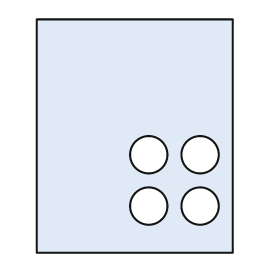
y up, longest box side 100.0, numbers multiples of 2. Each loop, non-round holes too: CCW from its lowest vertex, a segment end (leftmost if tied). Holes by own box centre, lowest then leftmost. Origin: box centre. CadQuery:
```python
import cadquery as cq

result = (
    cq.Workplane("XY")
    .moveTo(-42.0, -50.0)
    .lineTo(42.0, -50.0)
    .lineTo(42.0, 50.0)
    .lineTo(-42.0, 50.0)
    .close()
    .moveTo(6.0, -30.0)
    .circle(8.0)
    .moveTo(28.0, -30.0)
    .circle(8.0)
    .moveTo(6.0, -8.0)
    .circle(8.0)
    .moveTo(28.0, -8.0)
    .circle(8.0)
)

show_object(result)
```